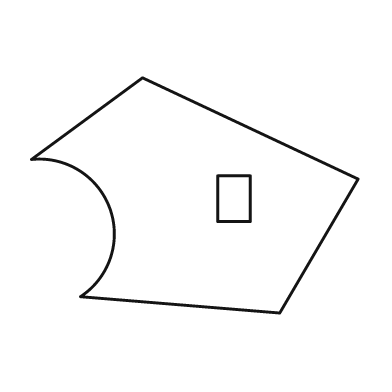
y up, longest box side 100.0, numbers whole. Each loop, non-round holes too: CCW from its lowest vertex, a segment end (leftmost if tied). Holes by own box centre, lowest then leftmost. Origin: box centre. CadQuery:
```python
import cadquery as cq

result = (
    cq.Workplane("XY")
    .moveTo(26.0, -36.0)
    .lineTo(50.0, 5.0)
    .lineTo(-16.0, 36.0)
    .lineTo(-50.0, 11.0)
    .threePointArc((-26.0, -4.0), (-35.0, -31.0))
    .close()
    .moveTo(7.0, -8.0)
    .lineTo(17.0, -8.0)
    .lineTo(17.0, 6.0)
    .lineTo(7.0, 6.0)
    .close()
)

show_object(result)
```